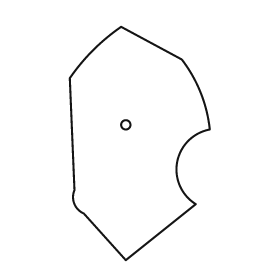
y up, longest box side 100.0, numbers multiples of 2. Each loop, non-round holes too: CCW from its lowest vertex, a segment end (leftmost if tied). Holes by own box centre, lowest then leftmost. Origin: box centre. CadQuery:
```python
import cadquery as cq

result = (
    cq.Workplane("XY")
    .moveTo(-6.0, -50.0)
    .lineTo(24.0, -26.0)
    .threePointArc((16.0, -8.0), (30.0, 6.0))
    .threePointArc((26.0, 22.0), (18.0, 36.0))
    .lineTo(-8.0, 50.0)
    .threePointArc((-20.0, 40.0), (-30.0, 28.0))
    .lineTo(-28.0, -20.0)
    .threePointArc((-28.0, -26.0), (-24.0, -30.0))
    .close()
    .moveTo(-6.0, 8.0)
    .circle(2.0)
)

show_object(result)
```